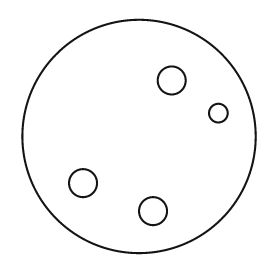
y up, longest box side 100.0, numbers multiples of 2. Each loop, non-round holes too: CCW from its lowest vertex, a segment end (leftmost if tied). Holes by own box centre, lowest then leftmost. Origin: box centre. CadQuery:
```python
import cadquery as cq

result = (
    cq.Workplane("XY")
    .moveTo(0.0, 0.0)
    .circle(50.0)
    .moveTo(6.0, -32.0)
    .circle(6.0)
    .moveTo(-24.0, -20.0)
    .circle(6.0)
    .moveTo(34.0, 10.0)
    .circle(4.0)
    .moveTo(14.0, 24.0)
    .circle(6.0)
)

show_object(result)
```